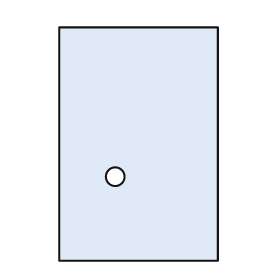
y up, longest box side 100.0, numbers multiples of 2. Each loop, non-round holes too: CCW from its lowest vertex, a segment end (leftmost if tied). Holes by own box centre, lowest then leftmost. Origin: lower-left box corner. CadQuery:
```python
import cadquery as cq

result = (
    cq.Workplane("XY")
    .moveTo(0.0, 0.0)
    .lineTo(68.0, 0.0)
    .lineTo(68.0, 100.0)
    .lineTo(0.0, 100.0)
    .close()
    .moveTo(24.0, 36.0)
    .circle(4.0)
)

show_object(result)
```